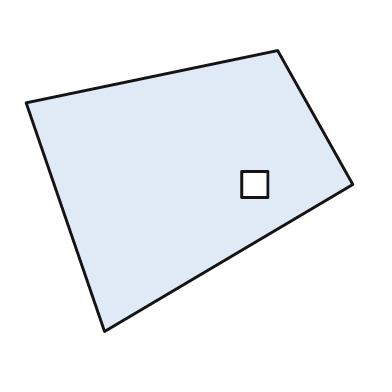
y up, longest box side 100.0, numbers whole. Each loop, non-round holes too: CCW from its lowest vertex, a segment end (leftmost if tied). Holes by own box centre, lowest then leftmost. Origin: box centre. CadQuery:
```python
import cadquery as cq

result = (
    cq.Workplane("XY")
    .moveTo(-26.0, -43.0)
    .lineTo(50.0, 2.0)
    .lineTo(27.0, 43.0)
    .lineTo(-50.0, 27.0)
    .close()
    .moveTo(16.0, -2.0)
    .lineTo(24.0, -2.0)
    .lineTo(24.0, 6.0)
    .lineTo(16.0, 6.0)
    .close()
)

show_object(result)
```